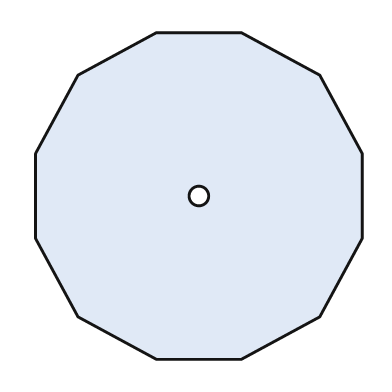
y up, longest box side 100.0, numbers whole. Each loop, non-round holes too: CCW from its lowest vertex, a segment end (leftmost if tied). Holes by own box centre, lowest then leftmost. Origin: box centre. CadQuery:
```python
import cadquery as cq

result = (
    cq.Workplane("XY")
    .moveTo(-13.0, -50.0)
    .lineTo(13.0, -50.0)
    .lineTo(37.0, -37.0)
    .lineTo(50.0, -13.0)
    .lineTo(50.0, 13.0)
    .lineTo(37.0, 37.0)
    .lineTo(13.0, 50.0)
    .lineTo(-13.0, 50.0)
    .lineTo(-37.0, 37.0)
    .lineTo(-50.0, 13.0)
    .lineTo(-50.0, -13.0)
    .lineTo(-37.0, -37.0)
    .close()
    .moveTo(0.0, 0.0)
    .circle(3.0)
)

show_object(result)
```